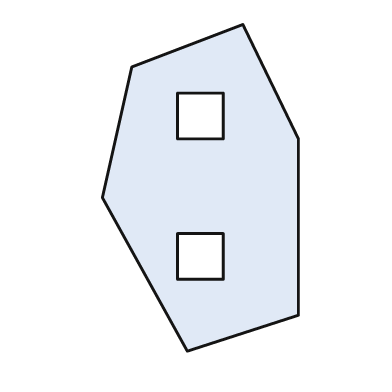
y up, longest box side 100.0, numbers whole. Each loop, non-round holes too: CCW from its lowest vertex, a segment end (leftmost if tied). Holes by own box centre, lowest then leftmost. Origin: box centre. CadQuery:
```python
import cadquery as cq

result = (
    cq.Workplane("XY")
    .moveTo(-4.0, -50.0)
    .lineTo(30.0, -39.0)
    .lineTo(30.0, 15.0)
    .lineTo(13.0, 50.0)
    .lineTo(-21.0, 37.0)
    .lineTo(-30.0, -3.0)
    .close()
    .moveTo(-7.0, -28.0)
    .lineTo(7.0, -28.0)
    .lineTo(7.0, -14.0)
    .lineTo(-7.0, -14.0)
    .close()
    .moveTo(-7.0, 15.0)
    .lineTo(7.0, 15.0)
    .lineTo(7.0, 29.0)
    .lineTo(-7.0, 29.0)
    .close()
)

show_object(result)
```